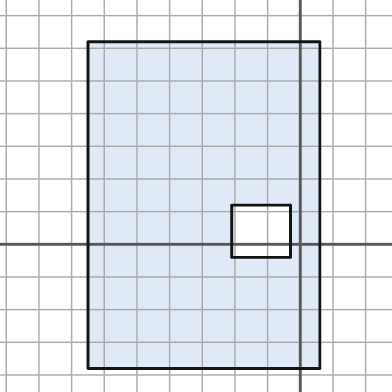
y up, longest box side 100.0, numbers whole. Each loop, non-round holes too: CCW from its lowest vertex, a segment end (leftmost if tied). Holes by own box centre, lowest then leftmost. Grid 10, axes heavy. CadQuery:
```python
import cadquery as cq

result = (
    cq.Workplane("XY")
    .moveTo(-65.0, -38.0)
    .lineTo(6.0, -38.0)
    .lineTo(6.0, 62.0)
    .lineTo(-65.0, 62.0)
    .close()
    .moveTo(-21.0, -4.0)
    .lineTo(-3.0, -4.0)
    .lineTo(-3.0, 12.0)
    .lineTo(-21.0, 12.0)
    .close()
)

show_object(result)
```